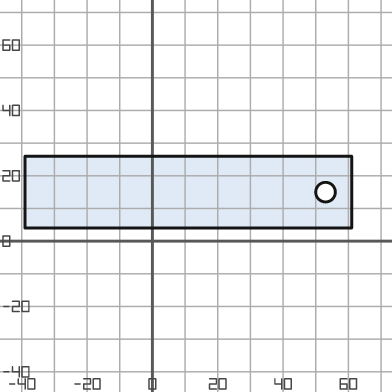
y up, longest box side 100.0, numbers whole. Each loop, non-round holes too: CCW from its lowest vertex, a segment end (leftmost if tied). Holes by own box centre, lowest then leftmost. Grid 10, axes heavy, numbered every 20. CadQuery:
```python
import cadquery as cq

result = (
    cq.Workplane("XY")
    .moveTo(-39.0, 4.0)
    .lineTo(61.0, 4.0)
    .lineTo(61.0, 26.0)
    .lineTo(-39.0, 26.0)
    .close()
    .moveTo(53.0, 15.0)
    .circle(3.0)
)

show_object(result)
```